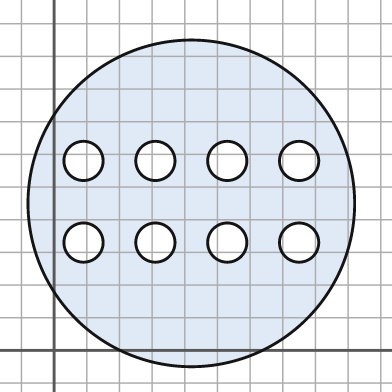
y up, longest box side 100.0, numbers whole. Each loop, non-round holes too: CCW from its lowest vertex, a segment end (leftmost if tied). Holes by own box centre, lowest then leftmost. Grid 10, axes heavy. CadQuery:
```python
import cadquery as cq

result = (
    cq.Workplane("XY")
    .moveTo(42.0, 45.0)
    .circle(50.0)
    .moveTo(9.0, 33.0)
    .circle(6.0)
    .moveTo(31.0, 33.0)
    .circle(6.0)
    .moveTo(53.0, 33.0)
    .circle(6.0)
    .moveTo(75.0, 33.0)
    .circle(6.0)
    .moveTo(9.0, 58.0)
    .circle(6.0)
    .moveTo(31.0, 58.0)
    .circle(6.0)
    .moveTo(53.0, 58.0)
    .circle(6.0)
    .moveTo(75.0, 58.0)
    .circle(6.0)
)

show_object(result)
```